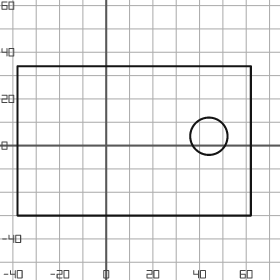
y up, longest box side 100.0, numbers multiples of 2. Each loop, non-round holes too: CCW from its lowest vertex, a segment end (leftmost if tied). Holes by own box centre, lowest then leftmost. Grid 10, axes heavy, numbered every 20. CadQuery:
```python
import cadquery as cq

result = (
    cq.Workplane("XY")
    .moveTo(-38.0, -30.0)
    .lineTo(62.0, -30.0)
    .lineTo(62.0, 34.0)
    .lineTo(-38.0, 34.0)
    .close()
    .moveTo(44.0, 4.0)
    .circle(8.0)
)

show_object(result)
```